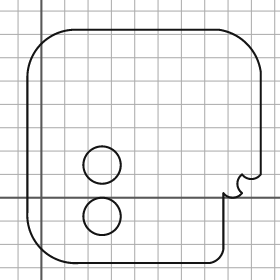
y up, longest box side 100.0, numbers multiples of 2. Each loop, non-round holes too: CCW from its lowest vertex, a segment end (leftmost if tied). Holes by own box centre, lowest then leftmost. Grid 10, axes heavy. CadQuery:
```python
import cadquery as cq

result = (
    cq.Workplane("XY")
    .moveTo(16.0, -28.0)
    .lineTo(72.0, -28.0)
    .threePointArc((76.0, -26.0), (78.0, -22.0))
    .lineTo(78.0, 2.0)
    .threePointArc((82.0, 0.0), (86.0, 2.0))
    .threePointArc((84.0, 6.0), (86.0, 10.0))
    .threePointArc((90.0, 8.0), (94.0, 10.0))
    .lineTo(94.0, 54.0)
    .threePointArc((88.0, 66.0), (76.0, 72.0))
    .lineTo(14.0, 72.0)
    .threePointArc((0.0, 66.0), (-6.0, 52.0))
    .lineTo(-6.0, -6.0)
    .threePointArc((0.0, -22.0), (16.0, -28.0))
    .close()
    .moveTo(26.0, -8.0)
    .circle(8.0)
    .moveTo(26.0, 14.0)
    .circle(8.0)
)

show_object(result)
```